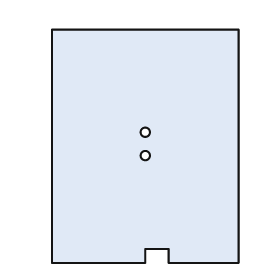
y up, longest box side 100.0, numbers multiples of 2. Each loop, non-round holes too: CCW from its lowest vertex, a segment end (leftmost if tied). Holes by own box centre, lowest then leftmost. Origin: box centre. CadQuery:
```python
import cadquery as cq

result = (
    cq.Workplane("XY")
    .moveTo(-40.0, -50.0)
    .lineTo(0.0, -50.0)
    .lineTo(0.0, -44.0)
    .lineTo(10.0, -44.0)
    .lineTo(10.0, -50.0)
    .lineTo(40.0, -50.0)
    .lineTo(40.0, 50.0)
    .lineTo(-40.0, 50.0)
    .close()
    .moveTo(0.0, -4.0)
    .circle(2.0)
    .moveTo(0.0, 6.0)
    .circle(2.0)
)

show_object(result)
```